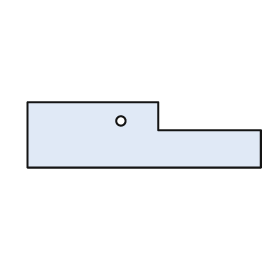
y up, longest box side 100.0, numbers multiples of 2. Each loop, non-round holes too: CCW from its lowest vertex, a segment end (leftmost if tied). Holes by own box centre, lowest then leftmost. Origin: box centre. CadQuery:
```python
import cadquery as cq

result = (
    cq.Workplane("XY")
    .moveTo(-50.0, -14.0)
    .lineTo(50.0, -14.0)
    .lineTo(50.0, 2.0)
    .lineTo(6.0, 2.0)
    .lineTo(6.0, 14.0)
    .lineTo(-50.0, 14.0)
    .close()
    .moveTo(-10.0, 6.0)
    .circle(2.0)
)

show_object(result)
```